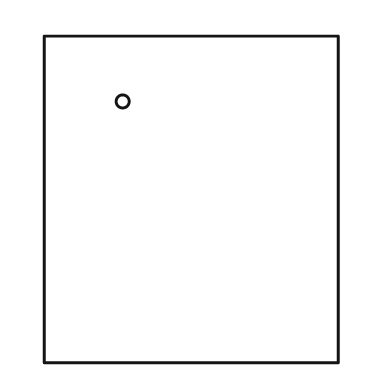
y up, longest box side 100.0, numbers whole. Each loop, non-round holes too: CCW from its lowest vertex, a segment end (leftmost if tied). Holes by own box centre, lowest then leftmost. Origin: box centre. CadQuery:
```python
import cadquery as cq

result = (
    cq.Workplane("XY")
    .moveTo(-45.0, -50.0)
    .lineTo(45.0, -50.0)
    .lineTo(45.0, 50.0)
    .lineTo(-45.0, 50.0)
    .close()
    .moveTo(-21.0, 30.0)
    .circle(2.0)
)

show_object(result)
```